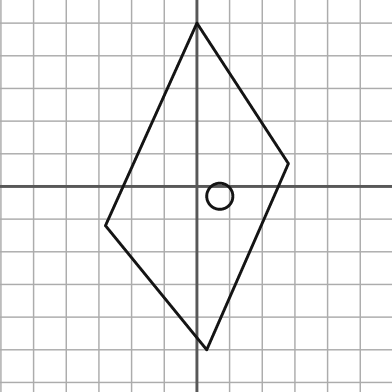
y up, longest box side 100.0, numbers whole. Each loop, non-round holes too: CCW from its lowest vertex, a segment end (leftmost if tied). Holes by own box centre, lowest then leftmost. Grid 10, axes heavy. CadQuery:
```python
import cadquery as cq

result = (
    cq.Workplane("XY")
    .moveTo(3.0, -50.0)
    .lineTo(28.0, 7.0)
    .lineTo(0.0, 50.0)
    .lineTo(-28.0, -12.0)
    .close()
    .moveTo(7.0, -3.0)
    .circle(4.0)
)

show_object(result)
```